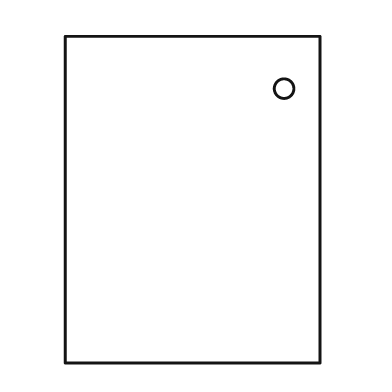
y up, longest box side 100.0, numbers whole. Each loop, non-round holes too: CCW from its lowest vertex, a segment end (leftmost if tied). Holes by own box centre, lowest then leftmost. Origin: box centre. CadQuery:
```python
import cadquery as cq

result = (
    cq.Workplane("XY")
    .moveTo(-39.0, -50.0)
    .lineTo(39.0, -50.0)
    .lineTo(39.0, 50.0)
    .lineTo(-39.0, 50.0)
    .close()
    .moveTo(28.0, 34.0)
    .circle(3.0)
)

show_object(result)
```